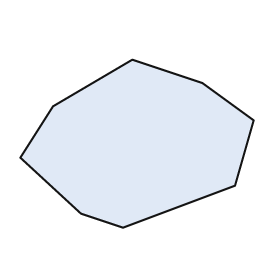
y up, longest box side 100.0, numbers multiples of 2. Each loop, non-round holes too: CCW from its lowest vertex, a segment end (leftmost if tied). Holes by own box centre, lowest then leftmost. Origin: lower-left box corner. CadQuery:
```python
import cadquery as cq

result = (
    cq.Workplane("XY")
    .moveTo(44.0, 0.0)
    .lineTo(92.0, 18.0)
    .lineTo(100.0, 46.0)
    .lineTo(78.0, 62.0)
    .lineTo(48.0, 72.0)
    .lineTo(14.0, 52.0)
    .lineTo(0.0, 30.0)
    .lineTo(26.0, 6.0)
    .close()
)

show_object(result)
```